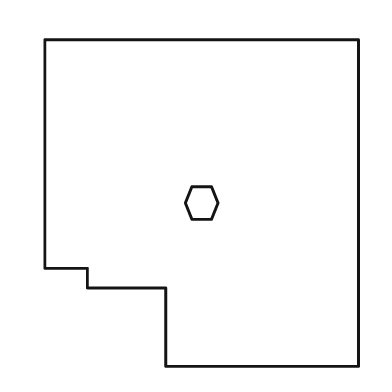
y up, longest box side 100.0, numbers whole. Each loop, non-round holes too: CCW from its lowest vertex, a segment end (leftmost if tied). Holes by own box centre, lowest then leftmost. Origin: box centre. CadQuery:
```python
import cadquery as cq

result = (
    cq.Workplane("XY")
    .moveTo(-11.0, -50.0)
    .lineTo(48.0, -50.0)
    .lineTo(48.0, 50.0)
    .lineTo(-48.0, 50.0)
    .lineTo(-48.0, -20.0)
    .lineTo(-35.0, -20.0)
    .lineTo(-35.0, -26.0)
    .lineTo(-11.0, -26.0)
    .close()
    .moveTo(-3.0, -5.0)
    .lineTo(3.0, -5.0)
    .lineTo(5.0, 0.0)
    .lineTo(3.0, 5.0)
    .lineTo(-3.0, 5.0)
    .lineTo(-5.0, 0.0)
    .close()
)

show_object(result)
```